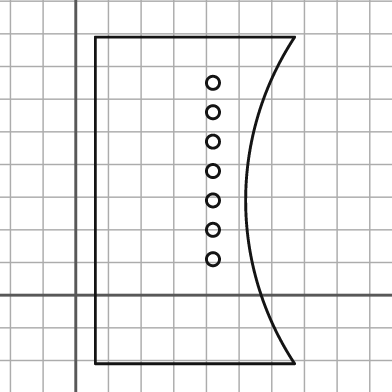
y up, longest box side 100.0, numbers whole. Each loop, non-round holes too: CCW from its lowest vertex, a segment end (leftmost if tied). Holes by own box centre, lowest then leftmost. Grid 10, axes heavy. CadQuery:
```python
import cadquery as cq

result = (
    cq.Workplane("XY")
    .moveTo(6.0, -21.0)
    .lineTo(67.0, -21.0)
    .threePointArc((52.0, 29.0), (67.0, 79.0))
    .lineTo(6.0, 79.0)
    .close()
    .moveTo(42.0, 11.0)
    .circle(2.0)
    .moveTo(42.0, 20.0)
    .circle(2.0)
    .moveTo(42.0, 29.0)
    .circle(2.0)
    .moveTo(42.0, 38.0)
    .circle(2.0)
    .moveTo(42.0, 47.0)
    .circle(2.0)
    .moveTo(42.0, 56.0)
    .circle(2.0)
    .moveTo(42.0, 65.0)
    .circle(2.0)
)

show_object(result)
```